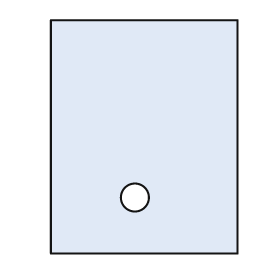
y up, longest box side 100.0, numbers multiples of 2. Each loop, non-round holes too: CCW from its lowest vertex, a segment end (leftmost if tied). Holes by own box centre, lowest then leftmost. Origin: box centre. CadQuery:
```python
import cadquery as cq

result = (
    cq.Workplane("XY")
    .moveTo(-40.0, -50.0)
    .lineTo(40.0, -50.0)
    .lineTo(40.0, 50.0)
    .lineTo(-40.0, 50.0)
    .close()
    .moveTo(-4.0, -26.0)
    .circle(6.0)
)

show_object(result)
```